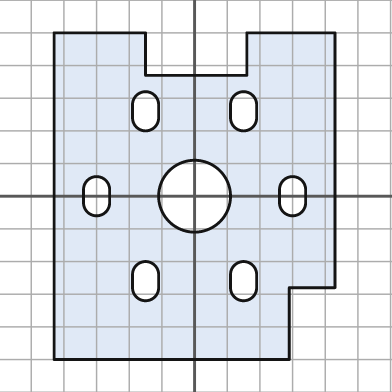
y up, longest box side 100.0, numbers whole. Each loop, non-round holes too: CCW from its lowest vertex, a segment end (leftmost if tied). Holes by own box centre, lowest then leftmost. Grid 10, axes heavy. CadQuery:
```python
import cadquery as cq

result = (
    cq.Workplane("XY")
    .moveTo(-43.0, -50.0)
    .lineTo(29.0, -50.0)
    .lineTo(29.0, -28.0)
    .lineTo(43.0, -28.0)
    .lineTo(43.0, 50.0)
    .lineTo(16.0, 50.0)
    .lineTo(16.0, 37.0)
    .lineTo(-15.0, 37.0)
    .lineTo(-15.0, 50.0)
    .lineTo(-43.0, 50.0)
    .close()
    .moveTo(-19.0, -28.0)
    .threePointArc((-15.0, -32.0), (-11.0, -28.0))
    .lineTo(-11.0, -24.0)
    .threePointArc((-15.0, -20.0), (-19.0, -24.0))
    .close()
    .moveTo(11.0, -28.0)
    .threePointArc((15.0, -32.0), (19.0, -28.0))
    .lineTo(19.0, -24.0)
    .threePointArc((15.0, -20.0), (11.0, -24.0))
    .close()
    .moveTo(-34.0, -2.0)
    .threePointArc((-30.0, -6.0), (-26.0, -2.0))
    .lineTo(-26.0, 2.0)
    .threePointArc((-30.0, 6.0), (-34.0, 2.0))
    .close()
    .moveTo(0.0, 0.0)
    .circle(11.0)
    .moveTo(26.0, -2.0)
    .threePointArc((30.0, -6.0), (34.0, -2.0))
    .lineTo(34.0, 2.0)
    .threePointArc((30.0, 6.0), (26.0, 2.0))
    .close()
    .moveTo(-19.0, 24.0)
    .threePointArc((-15.0, 20.0), (-11.0, 24.0))
    .lineTo(-11.0, 28.0)
    .threePointArc((-15.0, 32.0), (-19.0, 28.0))
    .close()
    .moveTo(11.0, 24.0)
    .threePointArc((15.0, 20.0), (19.0, 24.0))
    .lineTo(19.0, 28.0)
    .threePointArc((15.0, 32.0), (11.0, 28.0))
    .close()
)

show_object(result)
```